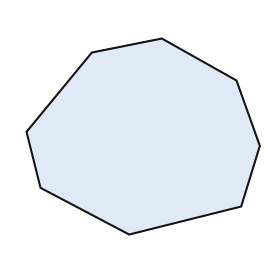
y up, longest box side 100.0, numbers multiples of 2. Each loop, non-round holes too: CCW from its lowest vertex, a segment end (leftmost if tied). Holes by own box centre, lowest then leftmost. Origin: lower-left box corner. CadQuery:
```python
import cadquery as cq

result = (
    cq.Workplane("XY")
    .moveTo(44.0, 0.0)
    .lineTo(92.0, 12.0)
    .lineTo(100.0, 38.0)
    .lineTo(90.0, 66.0)
    .lineTo(58.0, 84.0)
    .lineTo(28.0, 78.0)
    .lineTo(0.0, 44.0)
    .lineTo(6.0, 20.0)
    .close()
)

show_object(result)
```